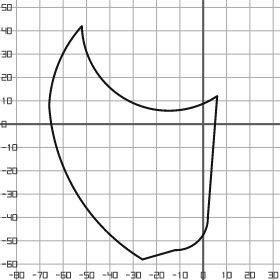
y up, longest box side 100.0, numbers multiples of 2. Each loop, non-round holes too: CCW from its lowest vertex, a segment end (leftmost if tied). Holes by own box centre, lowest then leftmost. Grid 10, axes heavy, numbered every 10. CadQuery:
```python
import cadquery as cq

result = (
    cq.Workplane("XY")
    .moveTo(-26.0, -58.0)
    .lineTo(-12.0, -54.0)
    .threePointArc((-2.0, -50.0), (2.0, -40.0))
    .lineTo(6.0, 12.0)
    .threePointArc((-32.0, 10.0), (-52.0, 42.0))
    .threePointArc((-62.0, 26.0), (-66.0, 8.0))
    .threePointArc((-54.0, -30.0), (-26.0, -58.0))
    .close()
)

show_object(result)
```